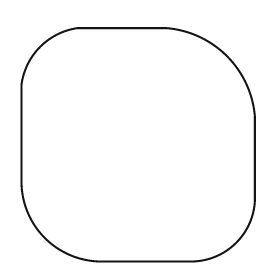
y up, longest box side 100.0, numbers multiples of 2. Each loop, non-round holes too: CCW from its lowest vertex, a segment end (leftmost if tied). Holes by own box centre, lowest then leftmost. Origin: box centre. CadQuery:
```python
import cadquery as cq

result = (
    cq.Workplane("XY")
    .moveTo(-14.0, -50.0)
    .lineTo(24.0, -50.0)
    .threePointArc((42.0, -42.0), (50.0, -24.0))
    .lineTo(50.0, 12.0)
    .threePointArc((38.0, 38.0), (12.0, 50.0))
    .lineTo(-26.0, 50.0)
    .threePointArc((-42.0, 42.0), (-50.0, 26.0))
    .lineTo(-50.0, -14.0)
    .threePointArc((-40.0, -40.0), (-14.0, -50.0))
    .close()
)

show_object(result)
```